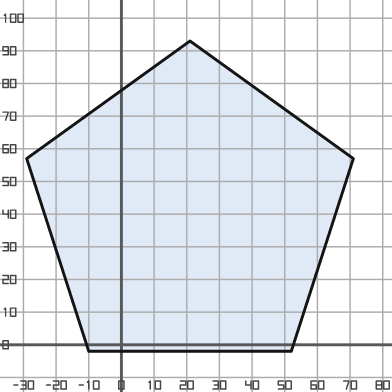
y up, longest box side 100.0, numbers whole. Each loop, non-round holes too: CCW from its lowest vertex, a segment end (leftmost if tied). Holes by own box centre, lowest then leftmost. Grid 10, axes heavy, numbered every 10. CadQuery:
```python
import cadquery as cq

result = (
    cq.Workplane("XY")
    .moveTo(-10.0, -2.0)
    .lineTo(52.0, -2.0)
    .lineTo(71.0, 57.0)
    .lineTo(21.0, 93.0)
    .lineTo(-29.0, 57.0)
    .close()
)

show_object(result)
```